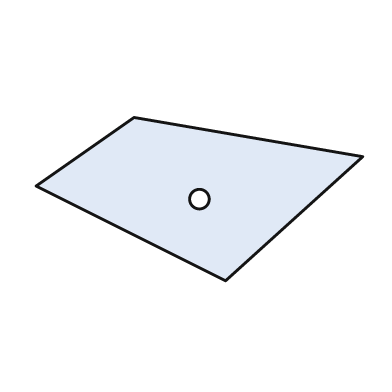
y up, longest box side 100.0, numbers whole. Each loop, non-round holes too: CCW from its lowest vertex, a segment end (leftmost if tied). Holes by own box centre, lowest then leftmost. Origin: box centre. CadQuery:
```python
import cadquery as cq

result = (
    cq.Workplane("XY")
    .moveTo(8.0, -25.0)
    .lineTo(50.0, 13.0)
    .lineTo(-20.0, 25.0)
    .lineTo(-50.0, 4.0)
    .close()
    .moveTo(0.0, 0.0)
    .circle(3.0)
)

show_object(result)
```